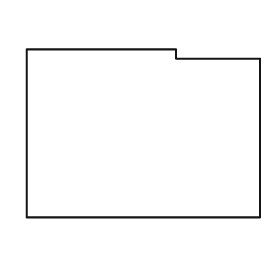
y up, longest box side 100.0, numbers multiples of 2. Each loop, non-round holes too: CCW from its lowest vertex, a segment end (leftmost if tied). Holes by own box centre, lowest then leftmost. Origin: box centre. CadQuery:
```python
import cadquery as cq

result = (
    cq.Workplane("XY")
    .moveTo(-50.0, -36.0)
    .lineTo(50.0, -36.0)
    .lineTo(50.0, 32.0)
    .lineTo(14.0, 32.0)
    .lineTo(14.0, 36.0)
    .lineTo(-50.0, 36.0)
    .close()
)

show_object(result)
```